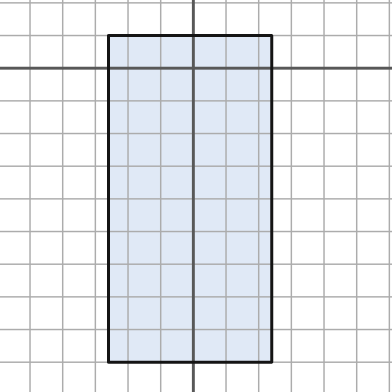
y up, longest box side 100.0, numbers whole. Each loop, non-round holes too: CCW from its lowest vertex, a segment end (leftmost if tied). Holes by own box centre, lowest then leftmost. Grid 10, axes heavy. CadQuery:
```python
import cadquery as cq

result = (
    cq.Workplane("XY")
    .moveTo(-26.0, -90.0)
    .lineTo(24.0, -90.0)
    .lineTo(24.0, 10.0)
    .lineTo(-26.0, 10.0)
    .close()
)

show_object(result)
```